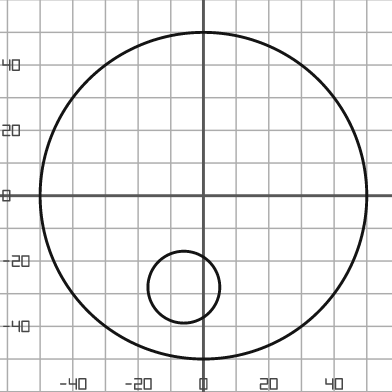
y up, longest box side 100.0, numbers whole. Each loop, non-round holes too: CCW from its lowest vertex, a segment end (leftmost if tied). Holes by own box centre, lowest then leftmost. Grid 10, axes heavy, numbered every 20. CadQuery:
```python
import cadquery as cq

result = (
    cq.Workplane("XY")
    .moveTo(0.0, 0.0)
    .circle(50.0)
    .moveTo(-6.0, -28.0)
    .circle(11.0)
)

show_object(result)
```